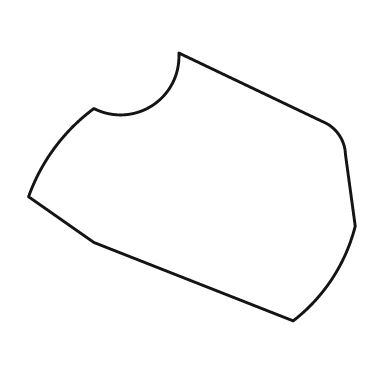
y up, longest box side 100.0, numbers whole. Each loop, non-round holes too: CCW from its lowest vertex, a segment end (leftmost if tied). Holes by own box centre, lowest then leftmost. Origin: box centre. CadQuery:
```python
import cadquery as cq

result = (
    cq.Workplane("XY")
    .moveTo(31.0, -41.0)
    .threePointArc((43.0, -28.0), (50.0, -12.0))
    .lineTo(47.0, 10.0)
    .threePointArc((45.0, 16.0), (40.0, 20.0))
    .lineTo(-4.0, 41.0)
    .threePointArc((-12.0, 25.0), (-30.0, 24.0))
    .threePointArc((-42.0, 12.0), (-50.0, -3.0))
    .lineTo(-30.0, -17.0)
    .close()
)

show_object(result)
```